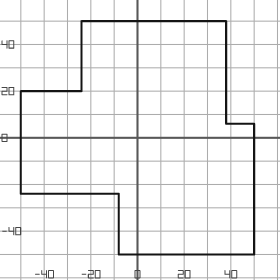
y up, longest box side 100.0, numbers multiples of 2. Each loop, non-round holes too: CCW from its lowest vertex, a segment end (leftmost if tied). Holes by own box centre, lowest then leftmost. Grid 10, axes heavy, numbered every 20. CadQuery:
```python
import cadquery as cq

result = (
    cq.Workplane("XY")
    .moveTo(-8.0, -50.0)
    .lineTo(50.0, -50.0)
    .lineTo(50.0, 6.0)
    .lineTo(38.0, 6.0)
    .lineTo(38.0, 50.0)
    .lineTo(-24.0, 50.0)
    .lineTo(-24.0, 20.0)
    .lineTo(-50.0, 20.0)
    .lineTo(-50.0, -24.0)
    .lineTo(-8.0, -24.0)
    .close()
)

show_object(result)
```